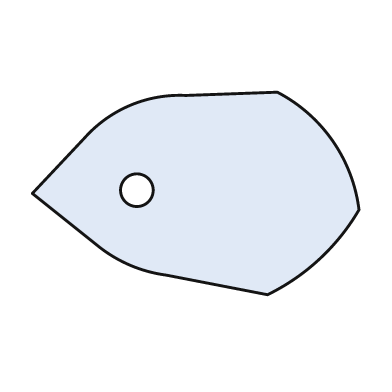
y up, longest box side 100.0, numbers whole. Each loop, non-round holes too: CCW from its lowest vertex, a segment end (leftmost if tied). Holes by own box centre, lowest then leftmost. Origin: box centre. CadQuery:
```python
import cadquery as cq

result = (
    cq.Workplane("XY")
    .moveTo(22.0, -31.0)
    .threePointArc((38.0, -20.0), (50.0, -5.0))
    .threePointArc((42.0, 16.0), (25.0, 31.0))
    .lineTo(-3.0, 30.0)
    .threePointArc((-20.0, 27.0), (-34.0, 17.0))
    .lineTo(-50.0, 0.0)
    .lineTo(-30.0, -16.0)
    .threePointArc((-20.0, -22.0), (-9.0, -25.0))
    .close()
    .moveTo(-18.0, 1.0)
    .circle(5.0)
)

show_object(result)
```